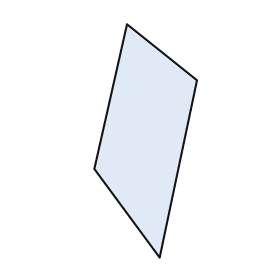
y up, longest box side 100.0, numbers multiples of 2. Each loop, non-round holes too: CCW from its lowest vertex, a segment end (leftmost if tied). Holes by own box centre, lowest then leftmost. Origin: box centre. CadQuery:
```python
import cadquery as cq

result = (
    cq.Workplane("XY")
    .moveTo(6.0, -50.0)
    .lineTo(22.0, 26.0)
    .lineTo(-8.0, 50.0)
    .lineTo(-22.0, -12.0)
    .close()
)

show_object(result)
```